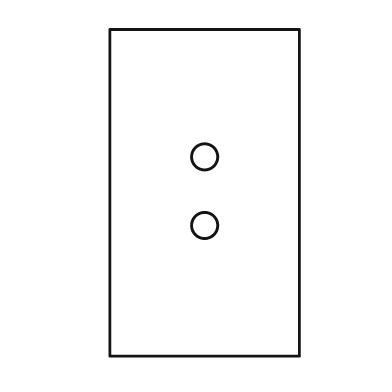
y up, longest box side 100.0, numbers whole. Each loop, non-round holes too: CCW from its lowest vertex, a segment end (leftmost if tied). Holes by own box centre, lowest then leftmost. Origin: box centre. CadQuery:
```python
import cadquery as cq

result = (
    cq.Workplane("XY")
    .moveTo(-29.0, -50.0)
    .lineTo(29.0, -50.0)
    .lineTo(29.0, 50.0)
    .lineTo(-29.0, 50.0)
    .close()
    .moveTo(0.0, -10.0)
    .circle(4.0)
    .moveTo(0.0, 11.0)
    .circle(4.0)
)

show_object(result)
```